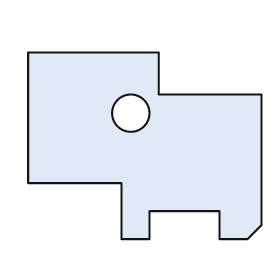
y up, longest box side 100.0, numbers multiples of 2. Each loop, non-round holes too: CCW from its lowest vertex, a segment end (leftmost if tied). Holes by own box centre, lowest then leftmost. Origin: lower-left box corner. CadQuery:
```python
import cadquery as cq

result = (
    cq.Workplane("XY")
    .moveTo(40.0, 0.0)
    .lineTo(52.0, 0.0)
    .lineTo(52.0, 12.0)
    .lineTo(82.0, 12.0)
    .lineTo(82.0, 0.0)
    .lineTo(94.0, 0.0)
    .lineTo(100.0, 6.0)
    .lineTo(100.0, 62.0)
    .lineTo(56.0, 62.0)
    .lineTo(56.0, 80.0)
    .lineTo(0.0, 80.0)
    .lineTo(0.0, 24.0)
    .lineTo(40.0, 24.0)
    .close()
    .moveTo(44.0, 54.0)
    .circle(8.0)
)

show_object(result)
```